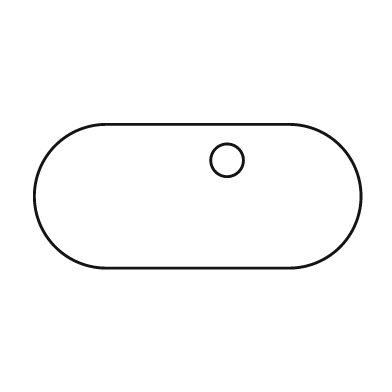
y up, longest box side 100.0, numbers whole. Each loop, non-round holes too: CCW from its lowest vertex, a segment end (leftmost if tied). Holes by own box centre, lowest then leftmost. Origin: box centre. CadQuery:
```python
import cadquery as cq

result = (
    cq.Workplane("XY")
    .moveTo(-28.0, -22.0)
    .lineTo(28.0, -22.0)
    .threePointArc((50.0, 0.0), (28.0, 22.0))
    .lineTo(-28.0, 22.0)
    .threePointArc((-50.0, 0.0), (-28.0, -22.0))
    .close()
    .moveTo(9.0, 11.0)
    .circle(5.0)
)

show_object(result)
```